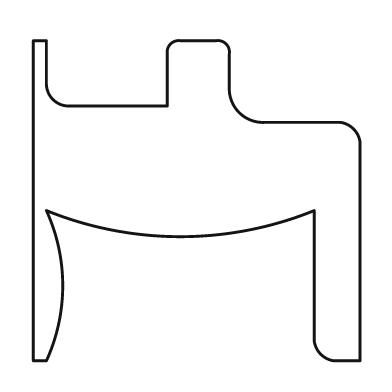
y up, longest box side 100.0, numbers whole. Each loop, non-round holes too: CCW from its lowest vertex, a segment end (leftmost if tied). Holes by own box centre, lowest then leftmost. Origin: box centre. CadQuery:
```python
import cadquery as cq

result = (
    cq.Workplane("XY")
    .moveTo(-50.0, -49.0)
    .lineTo(-46.0, -49.0)
    .threePointArc((-41.0, -26.0), (-46.0, -3.0))
    .threePointArc((-5.0, -11.0), (36.0, -3.0))
    .lineTo(36.0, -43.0)
    .threePointArc((38.0, -47.0), (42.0, -49.0))
    .lineTo(50.0, -49.0)
    .lineTo(50.0, 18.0)
    .threePointArc((48.0, 22.0), (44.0, 24.0))
    .lineTo(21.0, 24.0)
    .threePointArc((13.0, 27.0), (10.0, 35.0))
    .lineTo(10.0, 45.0)
    .threePointArc((9.0, 48.0), (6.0, 49.0))
    .lineTo(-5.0, 49.0)
    .threePointArc((-8.0, 48.0), (-9.0, 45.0))
    .lineTo(-9.0, 29.0)
    .lineTo(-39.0, 29.0)
    .threePointArc((-44.0, 31.0), (-46.0, 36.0))
    .lineTo(-46.0, 49.0)
    .lineTo(-50.0, 49.0)
    .close()
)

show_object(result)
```